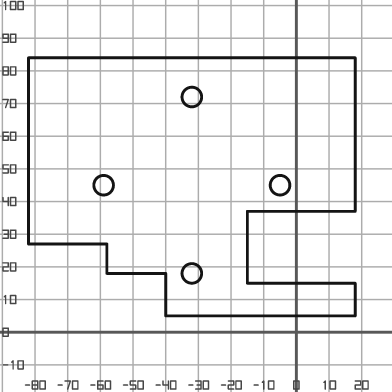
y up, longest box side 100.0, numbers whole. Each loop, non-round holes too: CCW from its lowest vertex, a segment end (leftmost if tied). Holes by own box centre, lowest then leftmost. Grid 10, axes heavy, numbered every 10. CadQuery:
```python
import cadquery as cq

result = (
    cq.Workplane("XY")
    .moveTo(-40.0, 5.0)
    .lineTo(18.0, 5.0)
    .lineTo(18.0, 15.0)
    .lineTo(-15.0, 15.0)
    .lineTo(-15.0, 37.0)
    .lineTo(18.0, 37.0)
    .lineTo(18.0, 84.0)
    .lineTo(-82.0, 84.0)
    .lineTo(-82.0, 27.0)
    .lineTo(-58.0, 27.0)
    .lineTo(-58.0, 18.0)
    .lineTo(-40.0, 18.0)
    .close()
    .moveTo(-32.0, 18.0)
    .circle(3.0)
    .moveTo(-59.0, 45.0)
    .circle(3.0)
    .moveTo(-5.0, 45.0)
    .circle(3.0)
    .moveTo(-32.0, 72.0)
    .circle(3.0)
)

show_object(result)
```